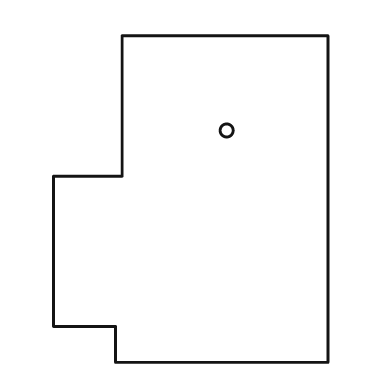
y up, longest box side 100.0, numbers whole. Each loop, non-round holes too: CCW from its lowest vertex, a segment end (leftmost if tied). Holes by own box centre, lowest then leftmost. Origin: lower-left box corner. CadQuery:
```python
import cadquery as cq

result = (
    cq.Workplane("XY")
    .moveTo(19.0, 0.0)
    .lineTo(84.0, 0.0)
    .lineTo(84.0, 100.0)
    .lineTo(21.0, 100.0)
    .lineTo(21.0, 57.0)
    .lineTo(0.0, 57.0)
    .lineTo(0.0, 11.0)
    .lineTo(19.0, 11.0)
    .close()
    .moveTo(53.0, 71.0)
    .circle(2.0)
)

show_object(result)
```